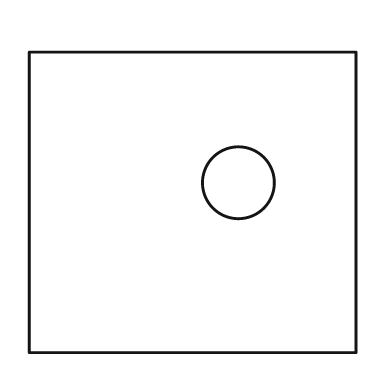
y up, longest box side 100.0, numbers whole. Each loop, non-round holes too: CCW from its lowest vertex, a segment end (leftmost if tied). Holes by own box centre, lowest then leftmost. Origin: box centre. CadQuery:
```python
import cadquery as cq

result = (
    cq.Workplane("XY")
    .moveTo(-50.0, -46.0)
    .lineTo(50.0, -46.0)
    .lineTo(50.0, 46.0)
    .lineTo(-50.0, 46.0)
    .close()
    .moveTo(14.0, 6.0)
    .circle(11.0)
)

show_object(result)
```